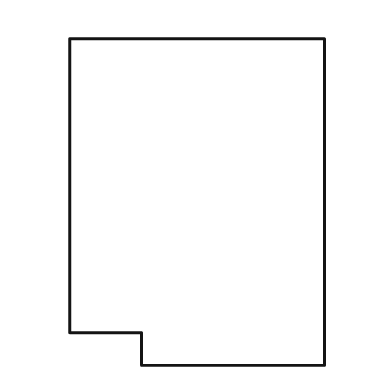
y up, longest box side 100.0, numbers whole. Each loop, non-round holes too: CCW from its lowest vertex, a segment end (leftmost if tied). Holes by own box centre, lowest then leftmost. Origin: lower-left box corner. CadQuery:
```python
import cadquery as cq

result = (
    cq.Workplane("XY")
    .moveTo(22.0, 0.0)
    .lineTo(78.0, 0.0)
    .lineTo(78.0, 100.0)
    .lineTo(0.0, 100.0)
    .lineTo(0.0, 10.0)
    .lineTo(22.0, 10.0)
    .close()
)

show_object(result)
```